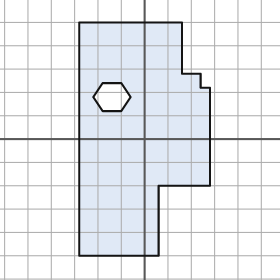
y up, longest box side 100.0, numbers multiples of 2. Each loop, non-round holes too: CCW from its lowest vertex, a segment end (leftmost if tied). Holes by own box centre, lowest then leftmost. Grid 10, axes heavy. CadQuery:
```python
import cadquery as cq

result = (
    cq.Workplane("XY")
    .moveTo(-28.0, -50.0)
    .lineTo(6.0, -50.0)
    .lineTo(6.0, -20.0)
    .lineTo(28.0, -20.0)
    .lineTo(28.0, 22.0)
    .lineTo(24.0, 22.0)
    .lineTo(24.0, 28.0)
    .lineTo(16.0, 28.0)
    .lineTo(16.0, 50.0)
    .lineTo(-28.0, 50.0)
    .close()
    .moveTo(-18.0, 12.0)
    .lineTo(-10.0, 12.0)
    .lineTo(-6.0, 18.0)
    .lineTo(-10.0, 24.0)
    .lineTo(-18.0, 24.0)
    .lineTo(-22.0, 18.0)
    .close()
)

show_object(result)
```